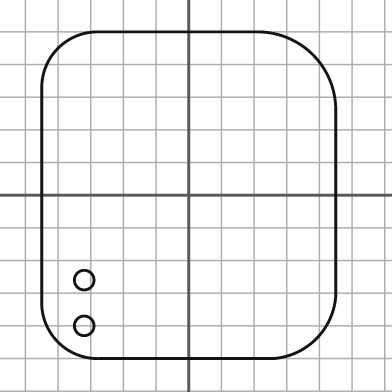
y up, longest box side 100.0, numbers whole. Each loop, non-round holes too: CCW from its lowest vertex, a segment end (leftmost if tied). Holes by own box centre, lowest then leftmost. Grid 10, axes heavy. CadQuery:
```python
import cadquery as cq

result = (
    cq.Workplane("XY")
    .moveTo(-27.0, -50.0)
    .lineTo(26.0, -50.0)
    .threePointArc((39.0, -44.0), (45.0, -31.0))
    .lineTo(45.0, 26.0)
    .threePointArc((38.0, 43.0), (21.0, 50.0))
    .lineTo(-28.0, 50.0)
    .threePointArc((-40.0, 45.0), (-45.0, 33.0))
    .lineTo(-45.0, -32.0)
    .threePointArc((-40.0, -45.0), (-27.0, -50.0))
    .close()
    .moveTo(-32.0, -40.0)
    .circle(3.0)
    .moveTo(-32.0, -26.0)
    .circle(3.0)
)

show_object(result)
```